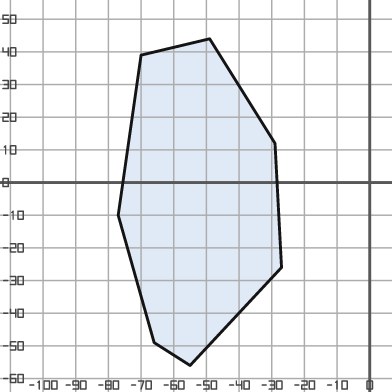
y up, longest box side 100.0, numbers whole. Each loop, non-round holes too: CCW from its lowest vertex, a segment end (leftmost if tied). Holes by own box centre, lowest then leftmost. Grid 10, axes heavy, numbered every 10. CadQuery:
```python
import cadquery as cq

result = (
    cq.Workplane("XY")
    .moveTo(-55.0, -56.0)
    .lineTo(-27.0, -26.0)
    .lineTo(-29.0, 12.0)
    .lineTo(-49.0, 44.0)
    .lineTo(-70.0, 39.0)
    .lineTo(-77.0, -10.0)
    .lineTo(-66.0, -49.0)
    .close()
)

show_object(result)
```